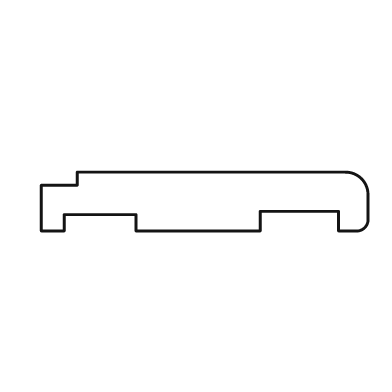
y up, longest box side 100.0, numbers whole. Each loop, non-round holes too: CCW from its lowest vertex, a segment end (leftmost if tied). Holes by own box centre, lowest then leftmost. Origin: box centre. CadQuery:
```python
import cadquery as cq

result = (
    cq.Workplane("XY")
    .moveTo(-50.0, -9.0)
    .lineTo(-43.0, -9.0)
    .lineTo(-43.0, -4.0)
    .lineTo(-21.0, -4.0)
    .lineTo(-21.0, -9.0)
    .lineTo(17.0, -9.0)
    .lineTo(17.0, -3.0)
    .lineTo(41.0, -3.0)
    .lineTo(41.0, -9.0)
    .lineTo(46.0, -9.0)
    .threePointArc((49.0, -8.0), (50.0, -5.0))
    .lineTo(50.0, 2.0)
    .threePointArc((48.0, 7.0), (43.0, 9.0))
    .lineTo(-39.0, 9.0)
    .lineTo(-39.0, 5.0)
    .lineTo(-50.0, 5.0)
    .close()
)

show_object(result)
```